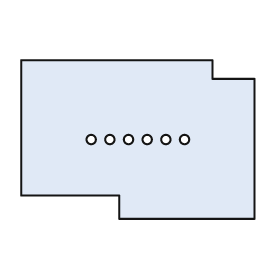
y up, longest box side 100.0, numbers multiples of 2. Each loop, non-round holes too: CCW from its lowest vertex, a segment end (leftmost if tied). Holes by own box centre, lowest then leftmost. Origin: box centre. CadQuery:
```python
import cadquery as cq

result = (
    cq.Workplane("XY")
    .moveTo(-8.0, -34.0)
    .lineTo(50.0, -34.0)
    .lineTo(50.0, 26.0)
    .lineTo(32.0, 26.0)
    .lineTo(32.0, 34.0)
    .lineTo(-50.0, 34.0)
    .lineTo(-50.0, -24.0)
    .lineTo(-8.0, -24.0)
    .close()
    .moveTo(-20.0, 0.0)
    .circle(2.0)
    .moveTo(-12.0, 0.0)
    .circle(2.0)
    .moveTo(-4.0, 0.0)
    .circle(2.0)
    .moveTo(4.0, 0.0)
    .circle(2.0)
    .moveTo(12.0, 0.0)
    .circle(2.0)
    .moveTo(20.0, 0.0)
    .circle(2.0)
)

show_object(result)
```